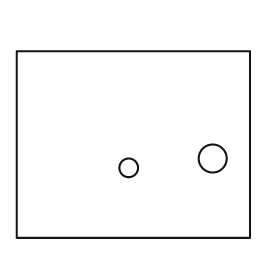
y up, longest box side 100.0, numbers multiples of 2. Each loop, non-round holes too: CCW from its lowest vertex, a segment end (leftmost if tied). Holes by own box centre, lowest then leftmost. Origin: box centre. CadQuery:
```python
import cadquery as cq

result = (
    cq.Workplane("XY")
    .moveTo(-50.0, -40.0)
    .lineTo(50.0, -40.0)
    .lineTo(50.0, 40.0)
    .lineTo(-50.0, 40.0)
    .close()
    .moveTo(-2.0, -10.0)
    .circle(4.0)
    .moveTo(34.0, -6.0)
    .circle(6.0)
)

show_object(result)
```